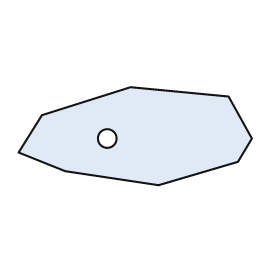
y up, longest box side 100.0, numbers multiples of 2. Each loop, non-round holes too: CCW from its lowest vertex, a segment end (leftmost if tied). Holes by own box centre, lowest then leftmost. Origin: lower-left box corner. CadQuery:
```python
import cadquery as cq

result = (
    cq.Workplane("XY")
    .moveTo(60.0, 0.0)
    .lineTo(94.0, 10.0)
    .lineTo(100.0, 20.0)
    .lineTo(90.0, 38.0)
    .lineTo(48.0, 42.0)
    .lineTo(10.0, 30.0)
    .lineTo(0.0, 14.0)
    .lineTo(20.0, 6.0)
    .close()
    .moveTo(38.0, 20.0)
    .circle(4.0)
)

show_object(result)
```